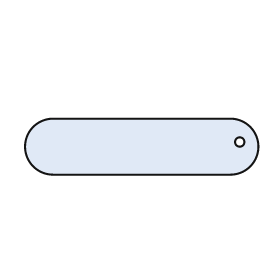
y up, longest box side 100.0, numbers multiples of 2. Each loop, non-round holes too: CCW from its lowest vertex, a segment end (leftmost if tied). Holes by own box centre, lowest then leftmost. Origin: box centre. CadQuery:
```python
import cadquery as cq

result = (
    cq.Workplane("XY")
    .moveTo(-38.0, -12.0)
    .lineTo(38.0, -12.0)
    .threePointArc((50.0, 0.0), (38.0, 12.0))
    .lineTo(-38.0, 12.0)
    .threePointArc((-50.0, 0.0), (-38.0, -12.0))
    .close()
    .moveTo(42.0, 2.0)
    .circle(2.0)
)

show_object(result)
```